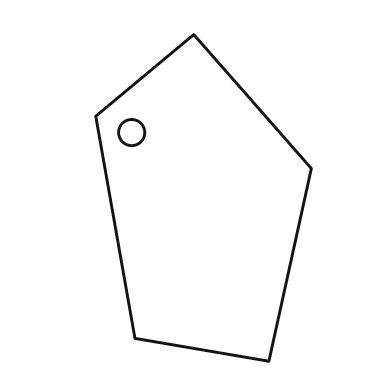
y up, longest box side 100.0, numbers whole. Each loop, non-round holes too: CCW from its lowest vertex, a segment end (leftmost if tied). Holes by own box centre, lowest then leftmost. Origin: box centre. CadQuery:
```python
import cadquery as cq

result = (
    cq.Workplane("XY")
    .moveTo(20.0, -50.0)
    .lineTo(33.0, 9.0)
    .lineTo(-3.0, 50.0)
    .lineTo(-33.0, 25.0)
    .lineTo(-21.0, -43.0)
    .close()
    .moveTo(-22.0, 20.0)
    .circle(4.0)
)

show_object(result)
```